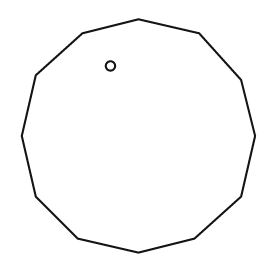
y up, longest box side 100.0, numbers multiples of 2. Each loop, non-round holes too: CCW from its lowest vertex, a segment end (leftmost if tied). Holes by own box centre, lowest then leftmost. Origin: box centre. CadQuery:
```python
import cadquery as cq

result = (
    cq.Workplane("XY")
    .moveTo(0.0, -50.0)
    .lineTo(24.0, -44.0)
    .lineTo(44.0, -26.0)
    .lineTo(50.0, 0.0)
    .lineTo(44.0, 24.0)
    .lineTo(26.0, 44.0)
    .lineTo(0.0, 50.0)
    .lineTo(-24.0, 44.0)
    .lineTo(-44.0, 26.0)
    .lineTo(-50.0, 0.0)
    .lineTo(-44.0, -26.0)
    .lineTo(-26.0, -44.0)
    .close()
    .moveTo(-12.0, 30.0)
    .circle(2.0)
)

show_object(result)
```